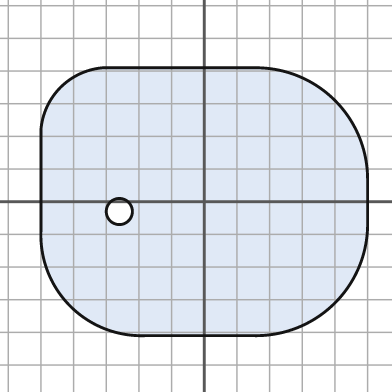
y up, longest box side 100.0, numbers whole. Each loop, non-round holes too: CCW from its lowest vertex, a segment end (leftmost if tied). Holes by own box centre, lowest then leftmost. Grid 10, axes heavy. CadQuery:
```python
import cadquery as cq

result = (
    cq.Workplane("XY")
    .moveTo(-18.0, -41.0)
    .lineTo(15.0, -41.0)
    .threePointArc((40.0, -31.0), (50.0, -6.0))
    .lineTo(50.0, 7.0)
    .threePointArc((40.0, 31.0), (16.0, 41.0))
    .lineTo(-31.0, 41.0)
    .threePointArc((-44.0, 35.0), (-50.0, 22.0))
    .lineTo(-50.0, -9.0)
    .threePointArc((-41.0, -32.0), (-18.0, -41.0))
    .close()
    .moveTo(-26.0, -3.0)
    .circle(4.0)
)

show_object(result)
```